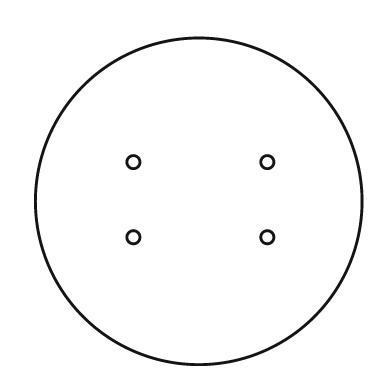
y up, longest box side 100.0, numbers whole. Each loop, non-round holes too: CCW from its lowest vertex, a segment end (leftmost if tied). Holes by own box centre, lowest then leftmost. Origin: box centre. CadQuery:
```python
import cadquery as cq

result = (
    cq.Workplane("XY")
    .moveTo(0.0, 0.0)
    .circle(50.0)
    .moveTo(-20.0, -11.0)
    .circle(2.0)
    .moveTo(21.0, -11.0)
    .circle(2.0)
    .moveTo(-20.0, 12.0)
    .circle(2.0)
    .moveTo(21.0, 12.0)
    .circle(2.0)
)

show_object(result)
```